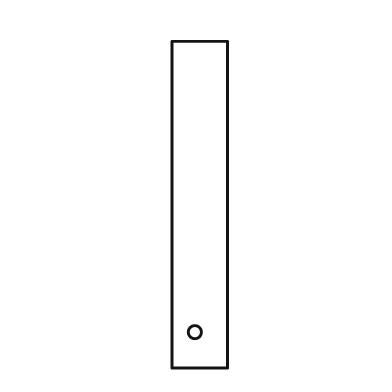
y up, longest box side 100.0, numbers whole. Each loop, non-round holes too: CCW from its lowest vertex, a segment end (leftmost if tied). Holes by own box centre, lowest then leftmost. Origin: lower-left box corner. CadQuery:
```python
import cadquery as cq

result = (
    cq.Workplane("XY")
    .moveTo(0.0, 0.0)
    .lineTo(17.0, 0.0)
    .lineTo(17.0, 100.0)
    .lineTo(0.0, 100.0)
    .close()
    .moveTo(7.0, 11.0)
    .circle(2.0)
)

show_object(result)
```